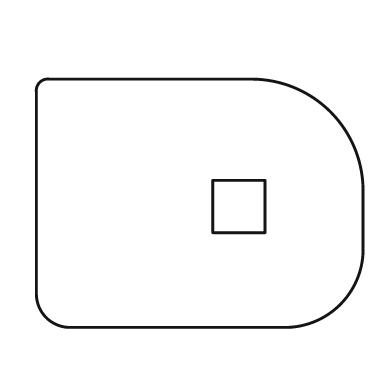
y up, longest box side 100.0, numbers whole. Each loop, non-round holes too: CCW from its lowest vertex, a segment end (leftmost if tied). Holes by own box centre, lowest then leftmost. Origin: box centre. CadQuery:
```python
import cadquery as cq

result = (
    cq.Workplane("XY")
    .moveTo(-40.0, -38.0)
    .lineTo(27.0, -38.0)
    .threePointArc((43.0, -31.0), (50.0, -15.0))
    .lineTo(50.0, 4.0)
    .threePointArc((40.0, 28.0), (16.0, 38.0))
    .lineTo(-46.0, 38.0)
    .threePointArc((-49.0, 37.0), (-50.0, 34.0))
    .lineTo(-50.0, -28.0)
    .threePointArc((-47.0, -35.0), (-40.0, -38.0))
    .close()
    .moveTo(4.0, -9.0)
    .lineTo(20.0, -9.0)
    .lineTo(20.0, 7.0)
    .lineTo(4.0, 7.0)
    .close()
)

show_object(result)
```